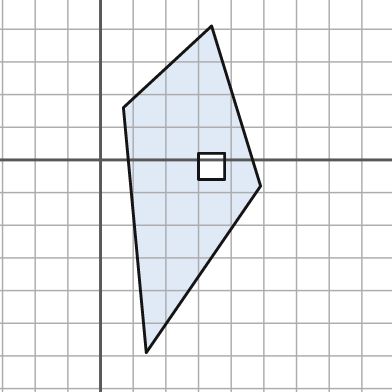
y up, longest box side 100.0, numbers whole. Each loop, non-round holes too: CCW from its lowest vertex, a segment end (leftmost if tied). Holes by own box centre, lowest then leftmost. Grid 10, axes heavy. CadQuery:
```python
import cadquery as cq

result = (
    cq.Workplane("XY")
    .moveTo(14.0, -59.0)
    .lineTo(49.0, -8.0)
    .lineTo(34.0, 41.0)
    .lineTo(7.0, 16.0)
    .close()
    .moveTo(30.0, -6.0)
    .lineTo(38.0, -6.0)
    .lineTo(38.0, 2.0)
    .lineTo(30.0, 2.0)
    .close()
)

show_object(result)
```